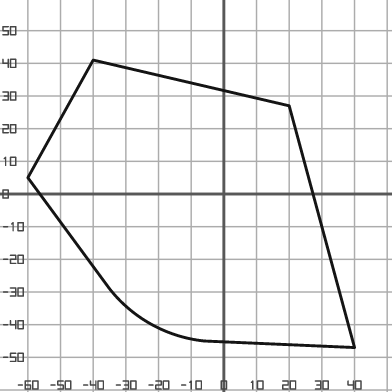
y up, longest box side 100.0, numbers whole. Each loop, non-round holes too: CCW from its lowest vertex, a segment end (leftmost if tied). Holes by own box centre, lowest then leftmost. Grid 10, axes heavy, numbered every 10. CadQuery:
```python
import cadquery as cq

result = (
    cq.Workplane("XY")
    .moveTo(40.0, -47.0)
    .lineTo(20.0, 27.0)
    .lineTo(-40.0, 41.0)
    .lineTo(-60.0, 5.0)
    .lineTo(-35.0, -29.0)
    .threePointArc((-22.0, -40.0), (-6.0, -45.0))
    .close()
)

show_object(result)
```